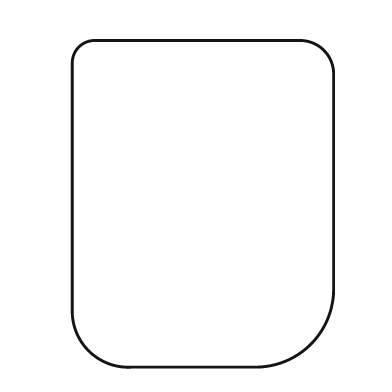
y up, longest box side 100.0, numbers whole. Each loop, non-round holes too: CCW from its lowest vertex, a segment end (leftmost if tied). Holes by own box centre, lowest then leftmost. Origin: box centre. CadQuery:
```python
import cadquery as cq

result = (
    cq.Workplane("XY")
    .moveTo(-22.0, -50.0)
    .lineTo(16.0, -50.0)
    .threePointArc((33.0, -43.0), (40.0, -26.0))
    .lineTo(40.0, 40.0)
    .threePointArc((37.0, 47.0), (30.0, 50.0))
    .lineTo(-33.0, 50.0)
    .threePointArc((-38.0, 48.0), (-40.0, 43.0))
    .lineTo(-40.0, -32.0)
    .threePointArc((-35.0, -45.0), (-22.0, -50.0))
    .close()
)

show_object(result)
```